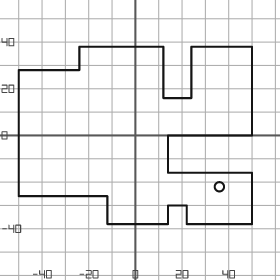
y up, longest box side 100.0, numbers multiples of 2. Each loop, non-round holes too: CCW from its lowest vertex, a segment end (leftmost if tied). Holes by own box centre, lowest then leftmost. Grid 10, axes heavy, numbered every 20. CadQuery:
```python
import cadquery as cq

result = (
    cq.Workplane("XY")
    .moveTo(-12.0, -38.0)
    .lineTo(14.0, -38.0)
    .lineTo(14.0, -30.0)
    .lineTo(22.0, -30.0)
    .lineTo(22.0, -38.0)
    .lineTo(50.0, -38.0)
    .lineTo(50.0, -16.0)
    .lineTo(14.0, -16.0)
    .lineTo(14.0, 0.0)
    .lineTo(50.0, 0.0)
    .lineTo(50.0, 38.0)
    .lineTo(24.0, 38.0)
    .lineTo(24.0, 16.0)
    .lineTo(12.0, 16.0)
    .lineTo(12.0, 38.0)
    .lineTo(-24.0, 38.0)
    .lineTo(-24.0, 28.0)
    .lineTo(-50.0, 28.0)
    .lineTo(-50.0, -26.0)
    .lineTo(-12.0, -26.0)
    .close()
    .moveTo(36.0, -22.0)
    .circle(2.0)
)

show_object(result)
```